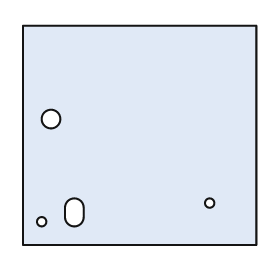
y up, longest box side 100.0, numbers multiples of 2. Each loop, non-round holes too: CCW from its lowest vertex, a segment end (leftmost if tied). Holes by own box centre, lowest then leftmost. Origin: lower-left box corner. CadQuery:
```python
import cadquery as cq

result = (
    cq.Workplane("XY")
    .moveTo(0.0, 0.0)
    .lineTo(100.0, 0.0)
    .lineTo(100.0, 94.0)
    .lineTo(0.0, 94.0)
    .close()
    .moveTo(8.0, 10.0)
    .circle(2.0)
    .moveTo(18.0, 12.0)
    .threePointArc((22.0, 8.0), (26.0, 12.0))
    .lineTo(26.0, 16.0)
    .threePointArc((22.0, 20.0), (18.0, 16.0))
    .close()
    .moveTo(80.0, 18.0)
    .circle(2.0)
    .moveTo(12.0, 54.0)
    .circle(4.0)
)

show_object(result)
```